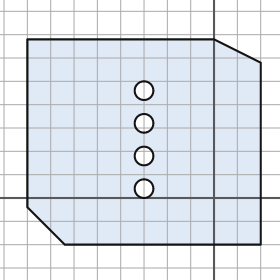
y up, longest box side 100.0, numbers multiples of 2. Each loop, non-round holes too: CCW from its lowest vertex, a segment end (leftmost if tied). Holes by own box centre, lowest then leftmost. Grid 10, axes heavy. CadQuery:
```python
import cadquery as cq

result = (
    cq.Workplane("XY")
    .moveTo(-64.0, -20.0)
    .lineTo(20.0, -20.0)
    .lineTo(20.0, 58.0)
    .lineTo(0.0, 68.0)
    .lineTo(-80.0, 68.0)
    .lineTo(-80.0, -4.0)
    .close()
    .moveTo(-30.0, 4.0)
    .circle(4.0)
    .moveTo(-30.0, 18.0)
    .circle(4.0)
    .moveTo(-30.0, 32.0)
    .circle(4.0)
    .moveTo(-30.0, 46.0)
    .circle(4.0)
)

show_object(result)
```